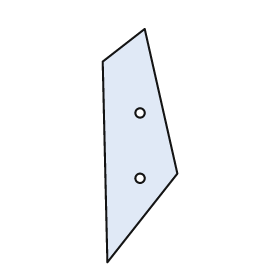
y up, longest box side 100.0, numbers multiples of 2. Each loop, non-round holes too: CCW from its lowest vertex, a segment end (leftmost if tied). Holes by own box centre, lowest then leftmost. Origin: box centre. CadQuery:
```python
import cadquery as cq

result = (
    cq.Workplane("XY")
    .moveTo(-14.0, -50.0)
    .lineTo(16.0, -12.0)
    .lineTo(2.0, 50.0)
    .lineTo(-16.0, 36.0)
    .close()
    .moveTo(0.0, -14.0)
    .circle(2.0)
    .moveTo(0.0, 14.0)
    .circle(2.0)
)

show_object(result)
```